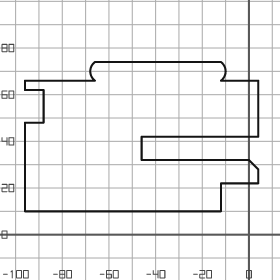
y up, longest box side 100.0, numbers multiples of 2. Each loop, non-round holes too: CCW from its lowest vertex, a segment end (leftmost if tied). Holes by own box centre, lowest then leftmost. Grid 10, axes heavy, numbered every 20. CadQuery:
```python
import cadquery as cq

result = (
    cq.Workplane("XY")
    .moveTo(-96.0, 10.0)
    .lineTo(-12.0, 10.0)
    .lineTo(-12.0, 22.0)
    .lineTo(4.0, 22.0)
    .lineTo(4.0, 28.0)
    .lineTo(0.0, 32.0)
    .lineTo(-46.0, 32.0)
    .lineTo(-46.0, 42.0)
    .lineTo(4.0, 42.0)
    .lineTo(4.0, 66.0)
    .lineTo(-12.0, 66.0)
    .threePointArc((-10.0, 70.0), (-12.0, 74.0))
    .lineTo(-66.0, 74.0)
    .threePointArc((-68.0, 70.0), (-66.0, 66.0))
    .lineTo(-96.0, 66.0)
    .lineTo(-96.0, 62.0)
    .lineTo(-88.0, 62.0)
    .lineTo(-88.0, 48.0)
    .lineTo(-96.0, 48.0)
    .close()
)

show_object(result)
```